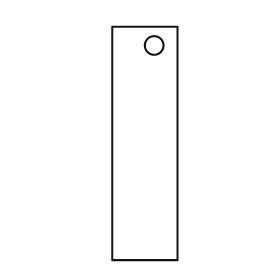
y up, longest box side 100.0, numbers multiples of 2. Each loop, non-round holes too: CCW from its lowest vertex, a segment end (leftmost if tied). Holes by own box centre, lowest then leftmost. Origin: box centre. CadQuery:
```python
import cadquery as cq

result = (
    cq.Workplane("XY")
    .moveTo(-14.0, -50.0)
    .lineTo(14.0, -50.0)
    .lineTo(14.0, 50.0)
    .lineTo(-14.0, 50.0)
    .close()
    .moveTo(4.0, 42.0)
    .circle(4.0)
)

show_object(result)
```